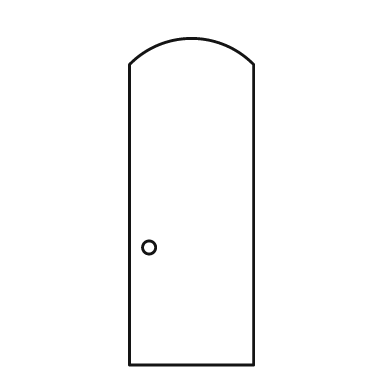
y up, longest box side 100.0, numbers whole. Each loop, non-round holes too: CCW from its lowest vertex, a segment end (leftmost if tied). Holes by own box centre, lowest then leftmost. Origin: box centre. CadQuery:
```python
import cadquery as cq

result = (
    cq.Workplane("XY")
    .moveTo(-19.0, -50.0)
    .lineTo(19.0, -50.0)
    .lineTo(19.0, 42.0)
    .threePointArc((0.0, 50.0), (-19.0, 42.0))
    .close()
    .moveTo(-13.0, -14.0)
    .circle(2.0)
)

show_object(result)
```